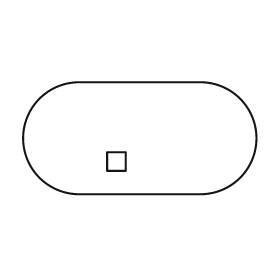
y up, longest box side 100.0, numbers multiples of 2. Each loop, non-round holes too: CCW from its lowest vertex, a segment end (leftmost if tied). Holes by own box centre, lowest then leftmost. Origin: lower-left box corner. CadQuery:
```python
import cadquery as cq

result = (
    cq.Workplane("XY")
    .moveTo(24.0, 0.0)
    .lineTo(76.0, 0.0)
    .threePointArc((100.0, 24.0), (76.0, 48.0))
    .lineTo(24.0, 48.0)
    .threePointArc((0.0, 24.0), (24.0, 0.0))
    .close()
    .moveTo(36.0, 10.0)
    .lineTo(44.0, 10.0)
    .lineTo(44.0, 18.0)
    .lineTo(36.0, 18.0)
    .close()
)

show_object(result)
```